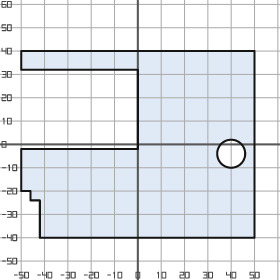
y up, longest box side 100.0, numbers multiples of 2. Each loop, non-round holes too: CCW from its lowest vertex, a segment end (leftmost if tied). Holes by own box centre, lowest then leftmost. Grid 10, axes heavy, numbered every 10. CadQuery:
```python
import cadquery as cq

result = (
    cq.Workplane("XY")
    .moveTo(-42.0, -40.0)
    .lineTo(50.0, -40.0)
    .lineTo(50.0, 40.0)
    .lineTo(-50.0, 40.0)
    .lineTo(-50.0, 32.0)
    .lineTo(0.0, 32.0)
    .lineTo(0.0, -2.0)
    .lineTo(-50.0, -2.0)
    .lineTo(-50.0, -20.0)
    .lineTo(-46.0, -20.0)
    .lineTo(-46.0, -24.0)
    .lineTo(-42.0, -24.0)
    .close()
    .moveTo(40.0, -4.0)
    .circle(6.0)
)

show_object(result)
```